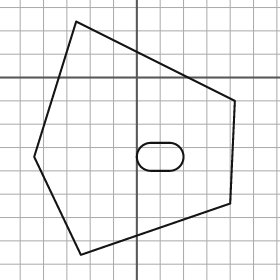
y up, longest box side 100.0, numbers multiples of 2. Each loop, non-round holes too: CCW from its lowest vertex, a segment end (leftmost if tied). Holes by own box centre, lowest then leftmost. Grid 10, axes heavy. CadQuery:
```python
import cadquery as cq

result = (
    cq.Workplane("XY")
    .moveTo(-24.0, -76.0)
    .lineTo(40.0, -54.0)
    .lineTo(42.0, -10.0)
    .lineTo(-26.0, 24.0)
    .lineTo(-44.0, -34.0)
    .close()
    .moveTo(6.0, -40.0)
    .lineTo(14.0, -40.0)
    .threePointArc((20.0, -34.0), (14.0, -28.0))
    .lineTo(6.0, -28.0)
    .threePointArc((0.0, -34.0), (6.0, -40.0))
    .close()
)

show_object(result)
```